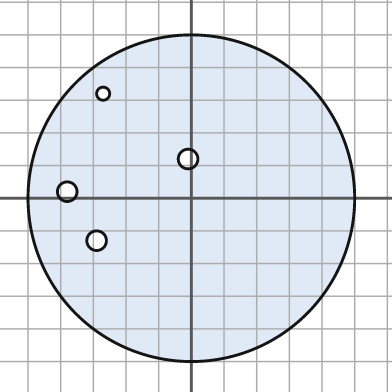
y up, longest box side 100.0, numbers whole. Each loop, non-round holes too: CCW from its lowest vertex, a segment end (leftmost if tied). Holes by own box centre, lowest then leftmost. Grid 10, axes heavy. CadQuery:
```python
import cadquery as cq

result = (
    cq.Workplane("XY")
    .moveTo(0.0, 0.0)
    .circle(50.0)
    .moveTo(-29.0, -13.0)
    .circle(3.0)
    .moveTo(-38.0, 2.0)
    .circle(3.0)
    .moveTo(-1.0, 12.0)
    .circle(3.0)
    .moveTo(-27.0, 32.0)
    .circle(2.0)
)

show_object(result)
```